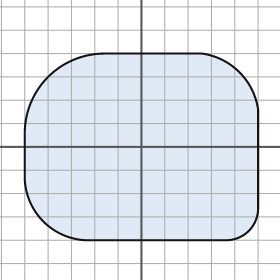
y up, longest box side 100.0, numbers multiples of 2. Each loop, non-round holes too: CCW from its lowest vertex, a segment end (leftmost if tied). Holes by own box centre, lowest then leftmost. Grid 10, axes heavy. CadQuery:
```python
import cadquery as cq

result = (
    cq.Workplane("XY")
    .moveTo(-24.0, -40.0)
    .lineTo(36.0, -40.0)
    .threePointArc((46.0, -36.0), (50.0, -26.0))
    .lineTo(50.0, 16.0)
    .threePointArc((42.0, 32.0), (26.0, 40.0))
    .lineTo(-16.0, 40.0)
    .threePointArc((-40.0, 30.0), (-50.0, 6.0))
    .lineTo(-50.0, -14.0)
    .threePointArc((-42.0, -32.0), (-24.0, -40.0))
    .close()
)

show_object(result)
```